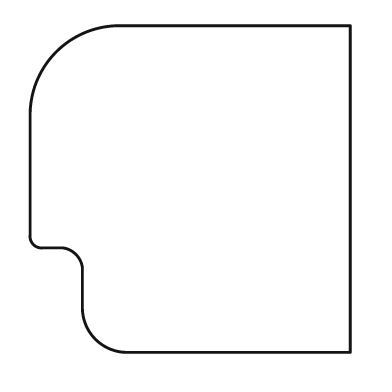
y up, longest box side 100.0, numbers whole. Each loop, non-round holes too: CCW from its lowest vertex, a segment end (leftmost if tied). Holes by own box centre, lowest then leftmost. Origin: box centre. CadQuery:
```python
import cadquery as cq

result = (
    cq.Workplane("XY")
    .moveTo(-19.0, -50.0)
    .lineTo(49.0, -50.0)
    .lineTo(49.0, 50.0)
    .lineTo(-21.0, 50.0)
    .threePointArc((-41.0, 42.0), (-49.0, 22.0))
    .lineTo(-49.0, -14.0)
    .threePointArc((-48.0, -17.0), (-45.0, -18.0))
    .lineTo(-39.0, -18.0)
    .threePointArc((-35.0, -20.0), (-33.0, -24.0))
    .lineTo(-33.0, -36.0)
    .threePointArc((-29.0, -46.0), (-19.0, -50.0))
    .close()
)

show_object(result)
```